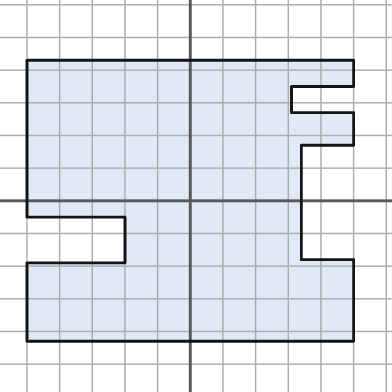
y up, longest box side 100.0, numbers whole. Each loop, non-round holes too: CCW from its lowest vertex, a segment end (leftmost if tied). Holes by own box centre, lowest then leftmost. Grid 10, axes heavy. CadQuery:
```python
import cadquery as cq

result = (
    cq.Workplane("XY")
    .moveTo(-50.0, -43.0)
    .lineTo(50.0, -43.0)
    .lineTo(50.0, -18.0)
    .lineTo(34.0, -18.0)
    .lineTo(34.0, 17.0)
    .lineTo(50.0, 17.0)
    .lineTo(50.0, 27.0)
    .lineTo(31.0, 27.0)
    .lineTo(31.0, 35.0)
    .lineTo(50.0, 35.0)
    .lineTo(50.0, 43.0)
    .lineTo(-50.0, 43.0)
    .lineTo(-50.0, -5.0)
    .lineTo(-20.0, -5.0)
    .lineTo(-20.0, -19.0)
    .lineTo(-50.0, -19.0)
    .close()
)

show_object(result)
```